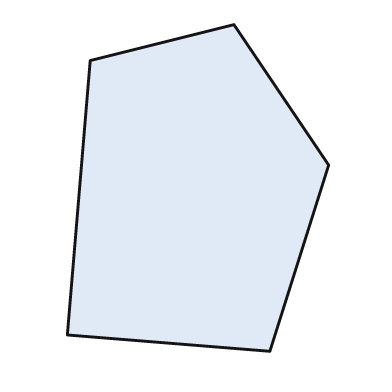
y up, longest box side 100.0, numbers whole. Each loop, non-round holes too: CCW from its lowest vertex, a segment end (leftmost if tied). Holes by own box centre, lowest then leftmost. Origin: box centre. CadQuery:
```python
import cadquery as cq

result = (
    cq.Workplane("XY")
    .moveTo(22.0, -50.0)
    .lineTo(40.0, 7.0)
    .lineTo(11.0, 50.0)
    .lineTo(-33.0, 39.0)
    .lineTo(-40.0, -45.0)
    .close()
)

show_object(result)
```